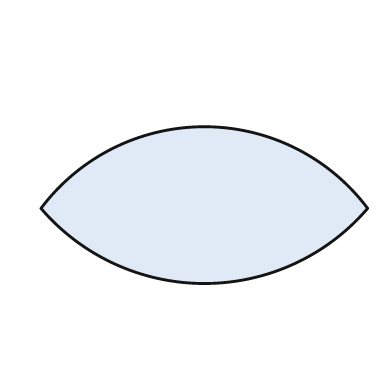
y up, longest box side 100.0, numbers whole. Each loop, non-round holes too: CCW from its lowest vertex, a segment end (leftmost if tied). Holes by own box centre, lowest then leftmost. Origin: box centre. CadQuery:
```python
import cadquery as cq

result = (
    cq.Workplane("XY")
    .moveTo(-50.0, -1.0)
    .threePointArc((0.0, -24.0), (50.0, -1.0))
    .threePointArc((0.0, 24.0), (-50.0, -1.0))
    .close()
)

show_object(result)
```